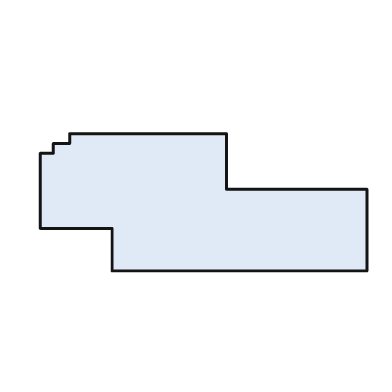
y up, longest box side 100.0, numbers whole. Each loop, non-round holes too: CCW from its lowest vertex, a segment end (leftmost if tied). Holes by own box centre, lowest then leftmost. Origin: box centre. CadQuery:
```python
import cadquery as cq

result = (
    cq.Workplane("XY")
    .moveTo(-28.0, -21.0)
    .lineTo(50.0, -21.0)
    .lineTo(50.0, 4.0)
    .lineTo(7.0, 4.0)
    .lineTo(7.0, 21.0)
    .lineTo(-41.0, 21.0)
    .lineTo(-41.0, 18.0)
    .lineTo(-46.0, 18.0)
    .lineTo(-46.0, 15.0)
    .lineTo(-50.0, 15.0)
    .lineTo(-50.0, -8.0)
    .lineTo(-28.0, -8.0)
    .close()
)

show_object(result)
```